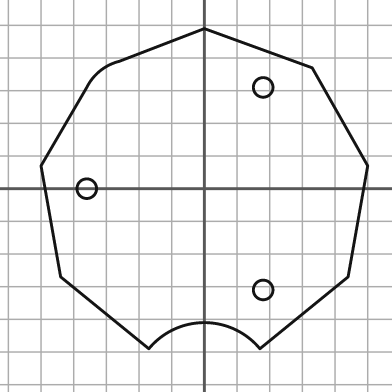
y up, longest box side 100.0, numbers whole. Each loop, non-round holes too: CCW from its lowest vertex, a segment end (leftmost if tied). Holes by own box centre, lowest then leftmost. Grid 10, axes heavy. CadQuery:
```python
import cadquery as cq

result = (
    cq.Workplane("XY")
    .moveTo(-17.0, -49.0)
    .threePointArc((0.0, -41.0), (17.0, -49.0))
    .lineTo(44.0, -27.0)
    .lineTo(50.0, 7.0)
    .lineTo(33.0, 37.0)
    .lineTo(0.0, 49.0)
    .lineTo(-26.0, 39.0)
    .threePointArc((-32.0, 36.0), (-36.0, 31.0))
    .lineTo(-50.0, 7.0)
    .lineTo(-44.0, -27.0)
    .close()
    .moveTo(18.0, -31.0)
    .circle(3.0)
    .moveTo(-36.0, 0.0)
    .circle(3.0)
    .moveTo(18.0, 31.0)
    .circle(3.0)
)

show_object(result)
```